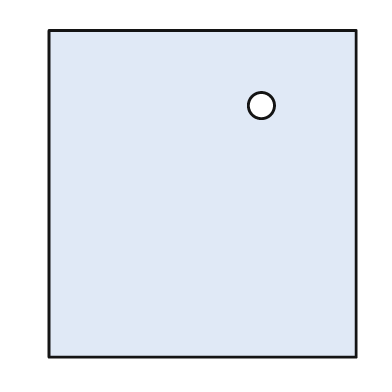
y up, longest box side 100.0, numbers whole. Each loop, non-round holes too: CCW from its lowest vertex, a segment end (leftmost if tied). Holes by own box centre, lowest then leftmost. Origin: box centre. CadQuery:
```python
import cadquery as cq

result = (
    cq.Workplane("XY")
    .moveTo(-47.0, -50.0)
    .lineTo(47.0, -50.0)
    .lineTo(47.0, 50.0)
    .lineTo(-47.0, 50.0)
    .close()
    .moveTo(18.0, 27.0)
    .circle(4.0)
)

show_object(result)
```